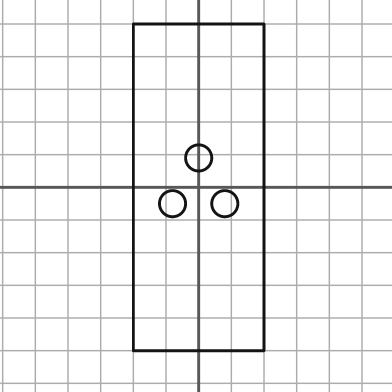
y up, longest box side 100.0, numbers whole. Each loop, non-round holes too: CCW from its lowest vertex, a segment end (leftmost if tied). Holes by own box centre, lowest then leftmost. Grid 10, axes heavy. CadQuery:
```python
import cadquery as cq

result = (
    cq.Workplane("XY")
    .moveTo(-20.0, -50.0)
    .lineTo(20.0, -50.0)
    .lineTo(20.0, 50.0)
    .lineTo(-20.0, 50.0)
    .close()
    .moveTo(-8.0, -5.0)
    .circle(4.0)
    .moveTo(8.0, -5.0)
    .circle(4.0)
    .moveTo(0.0, 9.0)
    .circle(4.0)
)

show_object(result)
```